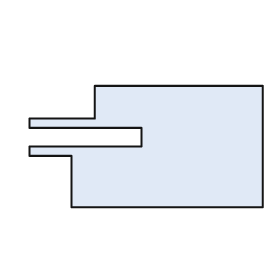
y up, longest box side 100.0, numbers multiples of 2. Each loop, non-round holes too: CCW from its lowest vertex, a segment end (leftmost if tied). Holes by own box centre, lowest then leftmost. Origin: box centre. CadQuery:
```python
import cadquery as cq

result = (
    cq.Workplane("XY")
    .moveTo(-32.0, -26.0)
    .lineTo(50.0, -26.0)
    .lineTo(50.0, 26.0)
    .lineTo(-22.0, 26.0)
    .lineTo(-22.0, 12.0)
    .lineTo(-50.0, 12.0)
    .lineTo(-50.0, 8.0)
    .lineTo(-2.0, 8.0)
    .lineTo(-2.0, 0.0)
    .lineTo(-50.0, 0.0)
    .lineTo(-50.0, -4.0)
    .lineTo(-32.0, -4.0)
    .close()
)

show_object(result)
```